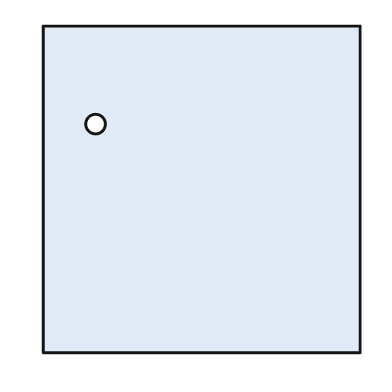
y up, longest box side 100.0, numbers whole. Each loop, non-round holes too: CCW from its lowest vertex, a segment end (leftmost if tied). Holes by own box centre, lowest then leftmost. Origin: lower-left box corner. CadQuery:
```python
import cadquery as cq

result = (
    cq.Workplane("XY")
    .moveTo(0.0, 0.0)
    .lineTo(97.0, 0.0)
    .lineTo(97.0, 100.0)
    .lineTo(0.0, 100.0)
    .close()
    .moveTo(16.0, 70.0)
    .circle(3.0)
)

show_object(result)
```